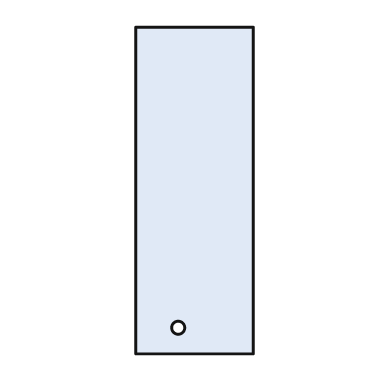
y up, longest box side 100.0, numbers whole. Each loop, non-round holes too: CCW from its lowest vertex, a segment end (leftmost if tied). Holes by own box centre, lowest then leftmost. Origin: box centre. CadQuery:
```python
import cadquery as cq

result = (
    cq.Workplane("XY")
    .moveTo(-18.0, -50.0)
    .lineTo(18.0, -50.0)
    .lineTo(18.0, 50.0)
    .lineTo(-18.0, 50.0)
    .close()
    .moveTo(-5.0, -42.0)
    .circle(2.0)
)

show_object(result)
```